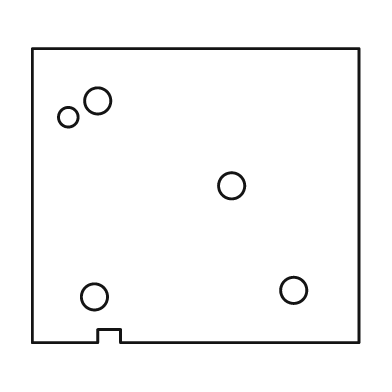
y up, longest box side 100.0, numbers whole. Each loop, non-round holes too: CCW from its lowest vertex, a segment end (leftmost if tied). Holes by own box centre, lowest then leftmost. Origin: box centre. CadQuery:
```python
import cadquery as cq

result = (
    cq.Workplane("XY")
    .moveTo(-50.0, -45.0)
    .lineTo(-30.0, -45.0)
    .lineTo(-30.0, -41.0)
    .lineTo(-23.0, -41.0)
    .lineTo(-23.0, -45.0)
    .lineTo(50.0, -45.0)
    .lineTo(50.0, 45.0)
    .lineTo(-50.0, 45.0)
    .close()
    .moveTo(-31.0, -31.0)
    .circle(4.0)
    .moveTo(30.0, -29.0)
    .circle(4.0)
    .moveTo(11.0, 3.0)
    .circle(4.0)
    .moveTo(-39.0, 24.0)
    .circle(3.0)
    .moveTo(-30.0, 29.0)
    .circle(4.0)
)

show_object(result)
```